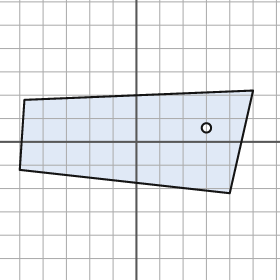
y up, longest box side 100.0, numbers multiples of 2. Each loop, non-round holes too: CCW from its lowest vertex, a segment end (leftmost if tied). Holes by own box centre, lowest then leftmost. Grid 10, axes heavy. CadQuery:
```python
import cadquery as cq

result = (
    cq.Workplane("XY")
    .moveTo(40.0, -22.0)
    .lineTo(50.0, 22.0)
    .lineTo(-48.0, 18.0)
    .lineTo(-50.0, -12.0)
    .close()
    .moveTo(30.0, 6.0)
    .circle(2.0)
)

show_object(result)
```